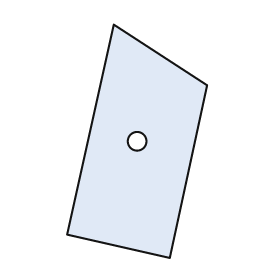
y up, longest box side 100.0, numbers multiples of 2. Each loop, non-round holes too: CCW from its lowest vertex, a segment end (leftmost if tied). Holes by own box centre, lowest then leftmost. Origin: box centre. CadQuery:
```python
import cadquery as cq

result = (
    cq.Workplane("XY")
    .moveTo(14.0, -50.0)
    .lineTo(30.0, 24.0)
    .lineTo(-10.0, 50.0)
    .lineTo(-30.0, -40.0)
    .close()
    .moveTo(0.0, 0.0)
    .circle(4.0)
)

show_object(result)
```